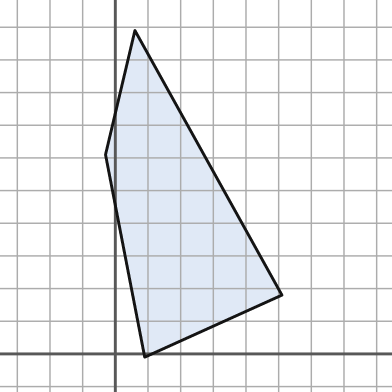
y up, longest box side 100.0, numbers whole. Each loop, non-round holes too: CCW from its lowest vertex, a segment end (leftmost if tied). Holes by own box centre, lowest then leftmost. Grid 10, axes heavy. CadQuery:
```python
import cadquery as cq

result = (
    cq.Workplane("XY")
    .moveTo(9.0, -1.0)
    .lineTo(51.0, 18.0)
    .lineTo(6.0, 99.0)
    .lineTo(-3.0, 61.0)
    .close()
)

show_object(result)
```